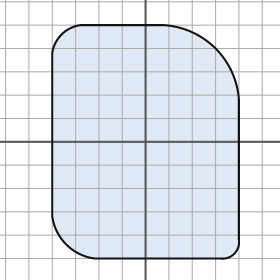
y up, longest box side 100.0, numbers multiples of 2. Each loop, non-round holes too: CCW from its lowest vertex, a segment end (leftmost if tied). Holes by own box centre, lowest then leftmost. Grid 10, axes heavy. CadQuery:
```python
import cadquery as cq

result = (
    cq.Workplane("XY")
    .moveTo(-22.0, -50.0)
    .lineTo(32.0, -50.0)
    .threePointArc((38.0, -48.0), (40.0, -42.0))
    .lineTo(40.0, 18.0)
    .threePointArc((30.0, 40.0), (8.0, 50.0))
    .lineTo(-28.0, 50.0)
    .threePointArc((-36.0, 46.0), (-40.0, 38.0))
    .lineTo(-40.0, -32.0)
    .threePointArc((-34.0, -44.0), (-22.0, -50.0))
    .close()
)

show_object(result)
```